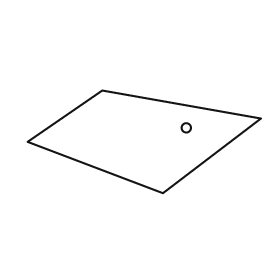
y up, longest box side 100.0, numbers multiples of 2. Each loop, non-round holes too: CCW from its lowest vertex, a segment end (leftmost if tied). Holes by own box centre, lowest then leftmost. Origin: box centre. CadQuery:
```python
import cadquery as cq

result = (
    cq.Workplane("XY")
    .moveTo(8.0, -22.0)
    .lineTo(50.0, 10.0)
    .lineTo(-18.0, 22.0)
    .lineTo(-50.0, 0.0)
    .close()
    .moveTo(18.0, 6.0)
    .circle(2.0)
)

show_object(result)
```